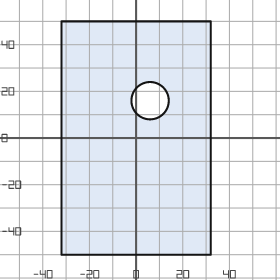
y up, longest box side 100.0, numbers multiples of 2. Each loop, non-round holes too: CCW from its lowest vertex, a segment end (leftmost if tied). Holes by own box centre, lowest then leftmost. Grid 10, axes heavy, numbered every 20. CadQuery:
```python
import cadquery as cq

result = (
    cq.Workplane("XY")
    .moveTo(-32.0, -50.0)
    .lineTo(32.0, -50.0)
    .lineTo(32.0, 50.0)
    .lineTo(-32.0, 50.0)
    .close()
    .moveTo(6.0, 16.0)
    .circle(8.0)
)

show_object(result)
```